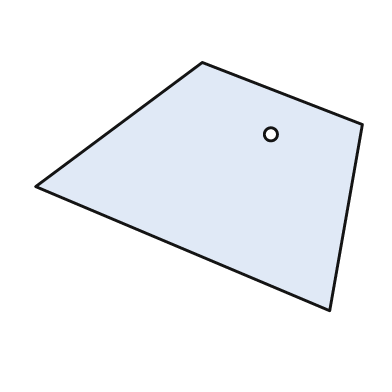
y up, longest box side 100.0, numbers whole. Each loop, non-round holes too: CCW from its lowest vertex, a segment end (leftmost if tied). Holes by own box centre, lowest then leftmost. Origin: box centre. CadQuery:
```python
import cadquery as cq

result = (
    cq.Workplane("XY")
    .moveTo(40.0, -38.0)
    .lineTo(50.0, 19.0)
    .lineTo(1.0, 38.0)
    .lineTo(-50.0, 0.0)
    .close()
    .moveTo(22.0, 16.0)
    .circle(2.0)
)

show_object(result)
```